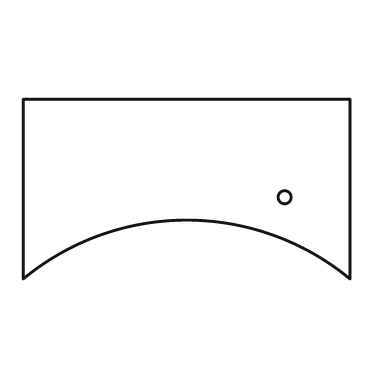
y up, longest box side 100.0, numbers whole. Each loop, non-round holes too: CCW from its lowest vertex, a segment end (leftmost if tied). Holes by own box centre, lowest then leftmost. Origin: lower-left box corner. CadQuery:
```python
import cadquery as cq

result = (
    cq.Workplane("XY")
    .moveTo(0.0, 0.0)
    .threePointArc((50.0, 18.0), (100.0, 0.0))
    .lineTo(100.0, 55.0)
    .lineTo(0.0, 55.0)
    .close()
    .moveTo(80.0, 25.0)
    .circle(2.0)
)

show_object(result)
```